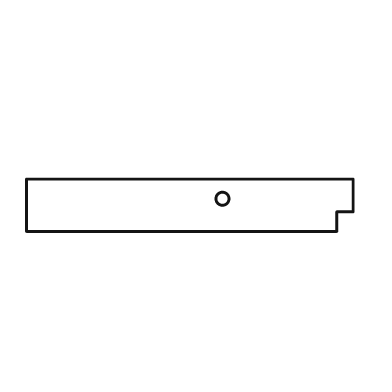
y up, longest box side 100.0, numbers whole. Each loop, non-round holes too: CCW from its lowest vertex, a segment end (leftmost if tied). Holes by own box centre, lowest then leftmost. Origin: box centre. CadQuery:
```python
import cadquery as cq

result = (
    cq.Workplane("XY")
    .moveTo(-50.0, -8.0)
    .lineTo(45.0, -8.0)
    .lineTo(45.0, -2.0)
    .lineTo(50.0, -2.0)
    .lineTo(50.0, 8.0)
    .lineTo(-50.0, 8.0)
    .close()
    .moveTo(10.0, 2.0)
    .circle(2.0)
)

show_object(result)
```